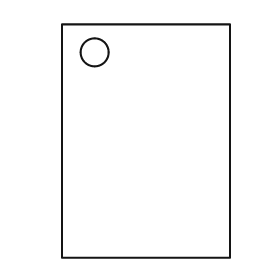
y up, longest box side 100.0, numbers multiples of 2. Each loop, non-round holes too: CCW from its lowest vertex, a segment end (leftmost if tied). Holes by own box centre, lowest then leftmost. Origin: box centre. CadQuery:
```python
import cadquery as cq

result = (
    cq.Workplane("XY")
    .moveTo(-36.0, -50.0)
    .lineTo(36.0, -50.0)
    .lineTo(36.0, 50.0)
    .lineTo(-36.0, 50.0)
    .close()
    .moveTo(-22.0, 38.0)
    .circle(6.0)
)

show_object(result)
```